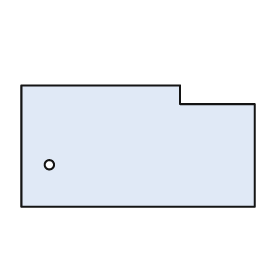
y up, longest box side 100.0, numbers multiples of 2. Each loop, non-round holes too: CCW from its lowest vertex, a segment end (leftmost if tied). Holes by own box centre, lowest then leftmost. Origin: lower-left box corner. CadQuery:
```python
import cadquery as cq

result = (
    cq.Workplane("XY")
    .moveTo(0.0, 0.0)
    .lineTo(100.0, 0.0)
    .lineTo(100.0, 44.0)
    .lineTo(68.0, 44.0)
    .lineTo(68.0, 52.0)
    .lineTo(0.0, 52.0)
    .close()
    .moveTo(12.0, 18.0)
    .circle(2.0)
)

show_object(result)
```